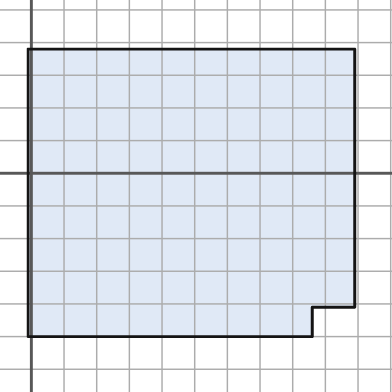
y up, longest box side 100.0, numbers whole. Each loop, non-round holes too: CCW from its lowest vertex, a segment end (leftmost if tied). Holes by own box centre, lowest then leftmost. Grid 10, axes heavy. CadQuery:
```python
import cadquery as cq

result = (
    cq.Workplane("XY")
    .moveTo(-1.0, -50.0)
    .lineTo(86.0, -50.0)
    .lineTo(86.0, -41.0)
    .lineTo(99.0, -41.0)
    .lineTo(99.0, 38.0)
    .lineTo(-1.0, 38.0)
    .close()
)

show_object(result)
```